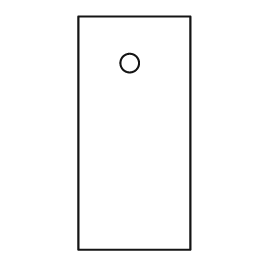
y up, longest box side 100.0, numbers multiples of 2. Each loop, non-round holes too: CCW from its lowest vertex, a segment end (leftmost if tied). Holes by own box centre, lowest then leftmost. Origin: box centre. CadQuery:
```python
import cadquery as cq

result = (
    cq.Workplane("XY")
    .moveTo(-24.0, -50.0)
    .lineTo(24.0, -50.0)
    .lineTo(24.0, 50.0)
    .lineTo(-24.0, 50.0)
    .close()
    .moveTo(-2.0, 30.0)
    .circle(4.0)
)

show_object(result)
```